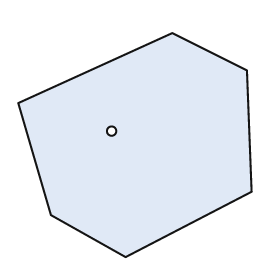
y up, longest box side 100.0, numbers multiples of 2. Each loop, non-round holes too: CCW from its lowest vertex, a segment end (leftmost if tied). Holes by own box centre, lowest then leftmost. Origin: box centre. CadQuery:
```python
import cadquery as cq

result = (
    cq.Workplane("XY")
    .moveTo(-4.0, -48.0)
    .lineTo(50.0, -20.0)
    .lineTo(48.0, 32.0)
    .lineTo(16.0, 48.0)
    .lineTo(-50.0, 18.0)
    .lineTo(-36.0, -30.0)
    .close()
    .moveTo(-10.0, 6.0)
    .circle(2.0)
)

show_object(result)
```